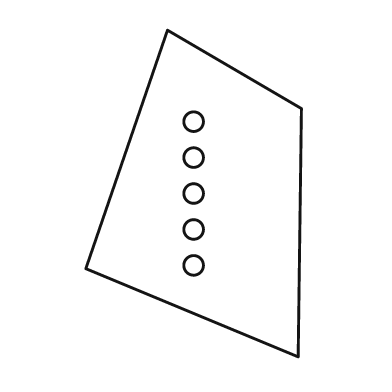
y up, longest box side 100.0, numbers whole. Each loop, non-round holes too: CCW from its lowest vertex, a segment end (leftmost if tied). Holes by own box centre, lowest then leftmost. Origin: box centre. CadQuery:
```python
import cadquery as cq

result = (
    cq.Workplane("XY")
    .moveTo(32.0, -50.0)
    .lineTo(33.0, 26.0)
    .lineTo(-8.0, 50.0)
    .lineTo(-33.0, -23.0)
    .close()
    .moveTo(0.0, -22.0)
    .circle(3.0)
    .moveTo(0.0, -11.0)
    .circle(3.0)
    .moveTo(0.0, 0.0)
    .circle(3.0)
    .moveTo(0.0, 11.0)
    .circle(3.0)
    .moveTo(0.0, 22.0)
    .circle(3.0)
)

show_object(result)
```